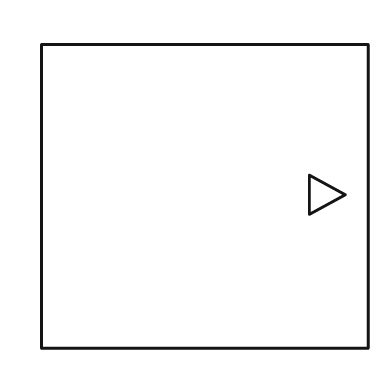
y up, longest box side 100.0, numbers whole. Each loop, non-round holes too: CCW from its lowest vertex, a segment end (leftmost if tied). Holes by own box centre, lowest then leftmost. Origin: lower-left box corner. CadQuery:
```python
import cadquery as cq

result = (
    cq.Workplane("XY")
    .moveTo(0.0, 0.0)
    .lineTo(100.0, 0.0)
    .lineTo(100.0, 93.0)
    .lineTo(0.0, 93.0)
    .close()
    .moveTo(82.0, 41.0)
    .lineTo(93.0, 47.0)
    .lineTo(82.0, 53.0)
    .close()
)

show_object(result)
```